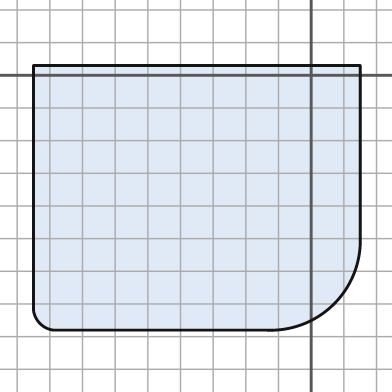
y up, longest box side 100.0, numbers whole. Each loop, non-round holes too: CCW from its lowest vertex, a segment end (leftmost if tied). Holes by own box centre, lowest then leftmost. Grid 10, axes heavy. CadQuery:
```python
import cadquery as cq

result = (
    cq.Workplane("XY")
    .moveTo(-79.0, -78.0)
    .lineTo(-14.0, -78.0)
    .threePointArc((7.0, -70.0), (15.0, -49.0))
    .lineTo(15.0, 3.0)
    .lineTo(-85.0, 3.0)
    .lineTo(-85.0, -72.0)
    .threePointArc((-83.0, -76.0), (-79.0, -78.0))
    .close()
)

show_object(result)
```